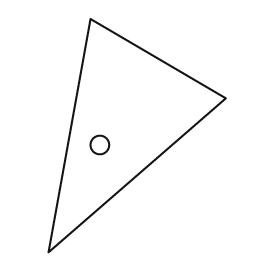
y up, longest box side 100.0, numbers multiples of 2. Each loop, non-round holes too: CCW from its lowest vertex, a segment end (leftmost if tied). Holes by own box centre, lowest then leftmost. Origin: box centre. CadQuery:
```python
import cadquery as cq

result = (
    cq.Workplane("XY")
    .moveTo(-38.0, -50.0)
    .lineTo(38.0, 16.0)
    .lineTo(-20.0, 50.0)
    .close()
    .moveTo(-16.0, -4.0)
    .circle(4.0)
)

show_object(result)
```